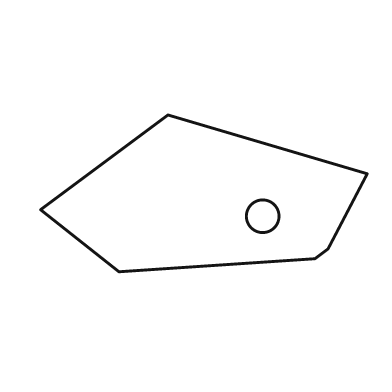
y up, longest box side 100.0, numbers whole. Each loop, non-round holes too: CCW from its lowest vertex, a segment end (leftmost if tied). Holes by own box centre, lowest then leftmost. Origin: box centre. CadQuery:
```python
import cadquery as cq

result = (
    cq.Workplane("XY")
    .moveTo(-26.0, -24.0)
    .lineTo(34.0, -20.0)
    .lineTo(38.0, -17.0)
    .lineTo(50.0, 6.0)
    .lineTo(-11.0, 24.0)
    .lineTo(-50.0, -5.0)
    .close()
    .moveTo(18.0, -7.0)
    .circle(5.0)
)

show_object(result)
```